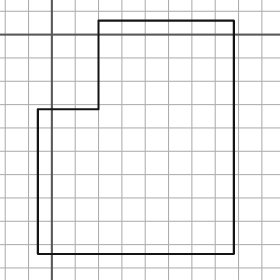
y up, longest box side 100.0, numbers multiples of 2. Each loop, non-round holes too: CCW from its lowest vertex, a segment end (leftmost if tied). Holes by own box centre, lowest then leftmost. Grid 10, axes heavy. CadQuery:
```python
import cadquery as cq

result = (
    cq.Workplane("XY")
    .moveTo(-6.0, -94.0)
    .lineTo(78.0, -94.0)
    .lineTo(78.0, 6.0)
    .lineTo(20.0, 6.0)
    .lineTo(20.0, -32.0)
    .lineTo(-6.0, -32.0)
    .close()
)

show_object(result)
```